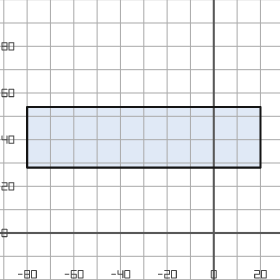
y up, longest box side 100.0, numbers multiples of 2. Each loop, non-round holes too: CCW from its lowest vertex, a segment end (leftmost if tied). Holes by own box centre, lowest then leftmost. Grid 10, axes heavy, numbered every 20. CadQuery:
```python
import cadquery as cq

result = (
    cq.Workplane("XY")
    .moveTo(-80.0, 28.0)
    .lineTo(20.0, 28.0)
    .lineTo(20.0, 54.0)
    .lineTo(-80.0, 54.0)
    .close()
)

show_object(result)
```